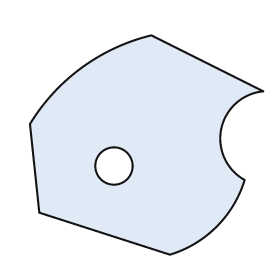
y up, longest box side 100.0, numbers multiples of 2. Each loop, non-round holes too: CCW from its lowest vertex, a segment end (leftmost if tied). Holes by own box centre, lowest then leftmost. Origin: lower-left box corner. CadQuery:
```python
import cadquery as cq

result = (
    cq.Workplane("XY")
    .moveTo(60.0, 0.0)
    .threePointArc((80.0, 12.0), (92.0, 32.0))
    .threePointArc((82.0, 54.0), (100.0, 70.0))
    .lineTo(52.0, 94.0)
    .threePointArc((22.0, 80.0), (0.0, 56.0))
    .lineTo(4.0, 18.0)
    .close()
    .moveTo(36.0, 38.0)
    .circle(8.0)
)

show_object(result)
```